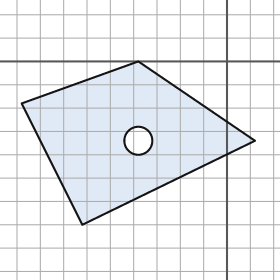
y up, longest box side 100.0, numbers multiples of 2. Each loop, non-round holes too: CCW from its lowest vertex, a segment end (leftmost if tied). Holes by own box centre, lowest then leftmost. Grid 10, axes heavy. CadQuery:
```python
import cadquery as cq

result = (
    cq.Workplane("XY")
    .moveTo(-62.0, -70.0)
    .lineTo(12.0, -34.0)
    .lineTo(-38.0, 0.0)
    .lineTo(-88.0, -18.0)
    .close()
    .moveTo(-38.0, -34.0)
    .circle(6.0)
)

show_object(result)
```